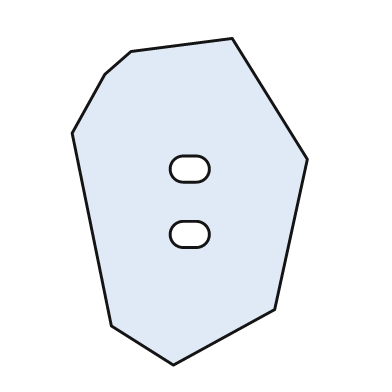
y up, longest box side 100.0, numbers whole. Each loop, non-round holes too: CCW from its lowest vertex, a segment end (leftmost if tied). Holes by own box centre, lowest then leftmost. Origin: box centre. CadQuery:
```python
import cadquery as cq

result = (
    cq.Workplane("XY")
    .moveTo(-5.0, -50.0)
    .lineTo(26.0, -33.0)
    .lineTo(36.0, 13.0)
    .lineTo(13.0, 50.0)
    .lineTo(-18.0, 46.0)
    .lineTo(-26.0, 39.0)
    .lineTo(-36.0, 21.0)
    .lineTo(-24.0, -38.0)
    .close()
    .moveTo(-2.0, -14.0)
    .lineTo(2.0, -14.0)
    .threePointArc((6.0, -10.0), (2.0, -6.0))
    .lineTo(-2.0, -6.0)
    .threePointArc((-6.0, -10.0), (-2.0, -14.0))
    .close()
    .moveTo(-2.0, 6.0)
    .lineTo(2.0, 6.0)
    .threePointArc((6.0, 10.0), (2.0, 14.0))
    .lineTo(-2.0, 14.0)
    .threePointArc((-6.0, 10.0), (-2.0, 6.0))
    .close()
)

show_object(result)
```